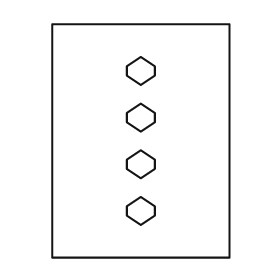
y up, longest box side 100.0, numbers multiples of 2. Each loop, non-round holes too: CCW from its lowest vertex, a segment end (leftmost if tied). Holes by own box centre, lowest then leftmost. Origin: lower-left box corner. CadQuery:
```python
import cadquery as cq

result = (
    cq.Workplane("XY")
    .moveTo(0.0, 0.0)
    .lineTo(76.0, 0.0)
    .lineTo(76.0, 100.0)
    .lineTo(0.0, 100.0)
    .close()
    .moveTo(38.0, 14.0)
    .lineTo(44.0, 18.0)
    .lineTo(44.0, 22.0)
    .lineTo(38.0, 26.0)
    .lineTo(32.0, 22.0)
    .lineTo(32.0, 18.0)
    .close()
    .moveTo(38.0, 34.0)
    .lineTo(44.0, 38.0)
    .lineTo(44.0, 42.0)
    .lineTo(38.0, 46.0)
    .lineTo(32.0, 42.0)
    .lineTo(32.0, 38.0)
    .close()
    .moveTo(38.0, 54.0)
    .lineTo(44.0, 58.0)
    .lineTo(44.0, 62.0)
    .lineTo(38.0, 66.0)
    .lineTo(32.0, 62.0)
    .lineTo(32.0, 58.0)
    .close()
    .moveTo(38.0, 74.0)
    .lineTo(44.0, 78.0)
    .lineTo(44.0, 82.0)
    .lineTo(38.0, 86.0)
    .lineTo(32.0, 82.0)
    .lineTo(32.0, 78.0)
    .close()
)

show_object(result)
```